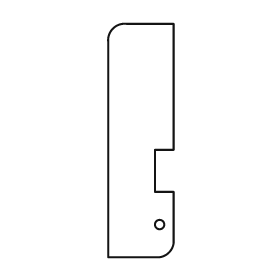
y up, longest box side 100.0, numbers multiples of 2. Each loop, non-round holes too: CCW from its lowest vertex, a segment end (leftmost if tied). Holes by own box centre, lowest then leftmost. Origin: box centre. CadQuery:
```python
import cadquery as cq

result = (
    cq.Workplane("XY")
    .moveTo(-14.0, -50.0)
    .lineTo(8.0, -50.0)
    .threePointArc((12.0, -48.0), (14.0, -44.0))
    .lineTo(14.0, -22.0)
    .lineTo(6.0, -22.0)
    .lineTo(6.0, -4.0)
    .lineTo(14.0, -4.0)
    .lineTo(14.0, 50.0)
    .lineTo(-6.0, 50.0)
    .threePointArc((-12.0, 48.0), (-14.0, 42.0))
    .close()
    .moveTo(8.0, -36.0)
    .circle(2.0)
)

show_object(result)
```